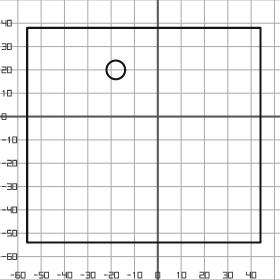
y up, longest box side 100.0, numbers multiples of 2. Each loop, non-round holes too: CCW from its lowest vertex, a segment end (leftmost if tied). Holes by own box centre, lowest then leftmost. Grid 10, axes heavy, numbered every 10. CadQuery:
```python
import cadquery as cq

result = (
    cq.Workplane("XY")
    .moveTo(-56.0, -54.0)
    .lineTo(44.0, -54.0)
    .lineTo(44.0, 38.0)
    .lineTo(-56.0, 38.0)
    .close()
    .moveTo(-18.0, 20.0)
    .circle(4.0)
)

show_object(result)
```